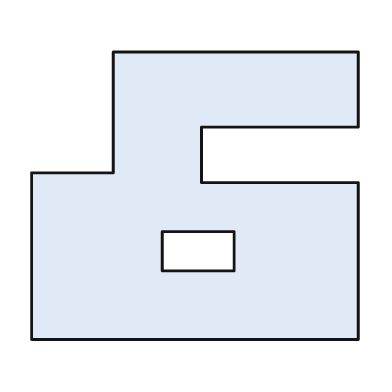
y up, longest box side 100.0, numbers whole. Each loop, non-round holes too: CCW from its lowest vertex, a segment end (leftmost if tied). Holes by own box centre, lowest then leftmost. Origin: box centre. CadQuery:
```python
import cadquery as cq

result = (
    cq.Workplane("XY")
    .moveTo(-50.0, -44.0)
    .lineTo(50.0, -44.0)
    .lineTo(50.0, 4.0)
    .lineTo(2.0, 4.0)
    .lineTo(2.0, 21.0)
    .lineTo(50.0, 21.0)
    .lineTo(50.0, 44.0)
    .lineTo(-25.0, 44.0)
    .lineTo(-25.0, 7.0)
    .lineTo(-50.0, 7.0)
    .close()
    .moveTo(-10.0, -23.0)
    .lineTo(12.0, -23.0)
    .lineTo(12.0, -11.0)
    .lineTo(-10.0, -11.0)
    .close()
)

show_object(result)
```